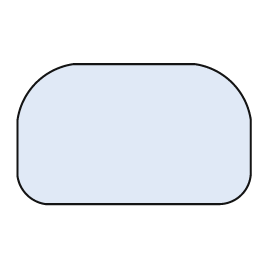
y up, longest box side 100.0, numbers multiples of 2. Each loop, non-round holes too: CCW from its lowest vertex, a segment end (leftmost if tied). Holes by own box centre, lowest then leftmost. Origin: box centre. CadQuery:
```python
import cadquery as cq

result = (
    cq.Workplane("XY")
    .moveTo(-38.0, -30.0)
    .lineTo(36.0, -30.0)
    .threePointArc((46.0, -26.0), (50.0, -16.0))
    .lineTo(50.0, 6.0)
    .threePointArc((42.0, 22.0), (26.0, 30.0))
    .lineTo(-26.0, 30.0)
    .threePointArc((-42.0, 22.0), (-50.0, 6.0))
    .lineTo(-50.0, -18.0)
    .threePointArc((-46.0, -26.0), (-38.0, -30.0))
    .close()
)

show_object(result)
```